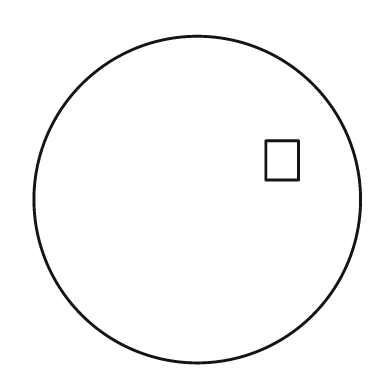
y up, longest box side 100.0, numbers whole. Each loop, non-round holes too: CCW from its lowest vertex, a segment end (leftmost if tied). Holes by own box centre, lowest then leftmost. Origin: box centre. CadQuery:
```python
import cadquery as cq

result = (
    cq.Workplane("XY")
    .moveTo(0.0, 0.0)
    .circle(50.0)
    .moveTo(21.0, 6.0)
    .lineTo(31.0, 6.0)
    .lineTo(31.0, 18.0)
    .lineTo(21.0, 18.0)
    .close()
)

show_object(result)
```